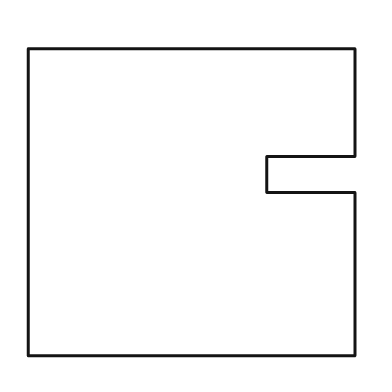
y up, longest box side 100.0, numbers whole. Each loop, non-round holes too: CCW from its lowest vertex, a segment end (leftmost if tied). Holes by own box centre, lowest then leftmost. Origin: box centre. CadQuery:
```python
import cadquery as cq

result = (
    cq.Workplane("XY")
    .moveTo(-50.0, -47.0)
    .lineTo(50.0, -47.0)
    .lineTo(50.0, 3.0)
    .lineTo(23.0, 3.0)
    .lineTo(23.0, 14.0)
    .lineTo(50.0, 14.0)
    .lineTo(50.0, 47.0)
    .lineTo(-50.0, 47.0)
    .close()
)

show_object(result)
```